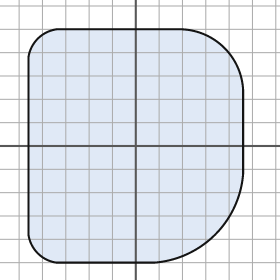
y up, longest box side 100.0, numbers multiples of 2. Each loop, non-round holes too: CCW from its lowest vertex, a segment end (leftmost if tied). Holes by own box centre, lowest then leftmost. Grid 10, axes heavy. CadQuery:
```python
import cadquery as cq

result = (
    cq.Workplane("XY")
    .moveTo(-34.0, -50.0)
    .lineTo(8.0, -50.0)
    .threePointArc((34.0, -38.0), (46.0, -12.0))
    .lineTo(46.0, 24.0)
    .threePointArc((38.0, 42.0), (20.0, 50.0))
    .lineTo(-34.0, 50.0)
    .threePointArc((-42.0, 46.0), (-46.0, 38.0))
    .lineTo(-46.0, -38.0)
    .threePointArc((-42.0, -46.0), (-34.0, -50.0))
    .close()
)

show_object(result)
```